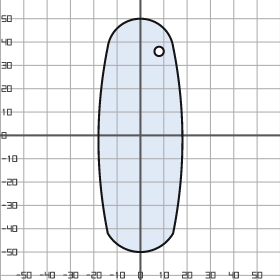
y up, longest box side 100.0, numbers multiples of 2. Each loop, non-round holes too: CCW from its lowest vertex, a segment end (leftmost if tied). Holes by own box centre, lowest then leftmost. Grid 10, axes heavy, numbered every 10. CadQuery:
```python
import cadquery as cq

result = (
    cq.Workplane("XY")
    .moveTo(-14.0, -42.0)
    .threePointArc((0.0, -50.0), (14.0, -42.0))
    .threePointArc((18.0, -2.0), (14.0, 38.0))
    .threePointArc((0.0, 50.0), (-14.0, 38.0))
    .threePointArc((-18.0, -2.0), (-14.0, -42.0))
    .close()
    .moveTo(8.0, 36.0)
    .circle(2.0)
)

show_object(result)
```